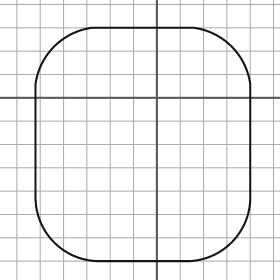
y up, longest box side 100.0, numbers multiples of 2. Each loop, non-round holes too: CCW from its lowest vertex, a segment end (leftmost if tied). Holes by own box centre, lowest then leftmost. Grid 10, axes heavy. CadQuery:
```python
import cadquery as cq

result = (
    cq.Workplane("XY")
    .moveTo(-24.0, -70.0)
    .lineTo(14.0, -70.0)
    .threePointArc((32.0, -62.0), (40.0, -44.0))
    .lineTo(40.0, 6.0)
    .threePointArc((32.0, 22.0), (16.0, 30.0))
    .lineTo(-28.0, 30.0)
    .threePointArc((-44.0, 22.0), (-52.0, 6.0))
    .lineTo(-52.0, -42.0)
    .threePointArc((-44.0, -62.0), (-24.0, -70.0))
    .close()
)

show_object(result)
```